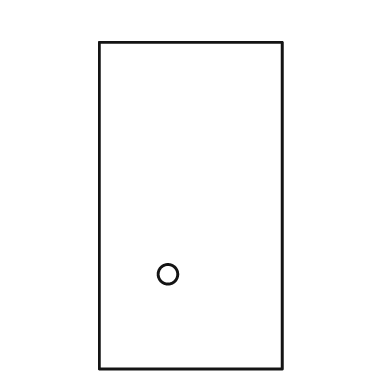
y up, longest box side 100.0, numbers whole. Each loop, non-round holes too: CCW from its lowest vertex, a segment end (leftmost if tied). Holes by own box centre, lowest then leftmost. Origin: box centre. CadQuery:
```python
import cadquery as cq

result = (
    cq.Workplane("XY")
    .moveTo(-28.0, -50.0)
    .lineTo(28.0, -50.0)
    .lineTo(28.0, 50.0)
    .lineTo(-28.0, 50.0)
    .close()
    .moveTo(-7.0, -21.0)
    .circle(3.0)
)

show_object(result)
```